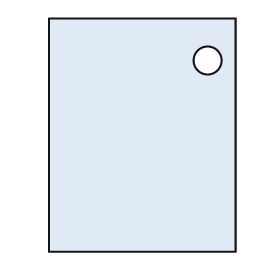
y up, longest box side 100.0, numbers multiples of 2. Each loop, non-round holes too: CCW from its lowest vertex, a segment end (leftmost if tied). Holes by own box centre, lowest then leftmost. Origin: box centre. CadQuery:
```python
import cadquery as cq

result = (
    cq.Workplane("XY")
    .moveTo(-40.0, -50.0)
    .lineTo(40.0, -50.0)
    .lineTo(40.0, 50.0)
    .lineTo(-40.0, 50.0)
    .close()
    .moveTo(28.0, 32.0)
    .circle(6.0)
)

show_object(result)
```